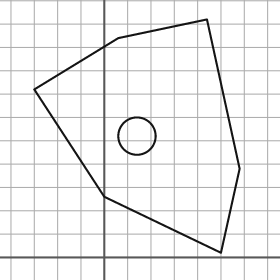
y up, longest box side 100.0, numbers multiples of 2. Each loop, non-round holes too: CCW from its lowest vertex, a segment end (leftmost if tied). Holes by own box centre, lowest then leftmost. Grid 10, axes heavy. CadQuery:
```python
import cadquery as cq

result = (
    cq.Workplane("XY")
    .moveTo(50.0, 2.0)
    .lineTo(58.0, 38.0)
    .lineTo(44.0, 102.0)
    .lineTo(6.0, 94.0)
    .lineTo(-30.0, 72.0)
    .lineTo(0.0, 26.0)
    .close()
    .moveTo(14.0, 52.0)
    .circle(8.0)
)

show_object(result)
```